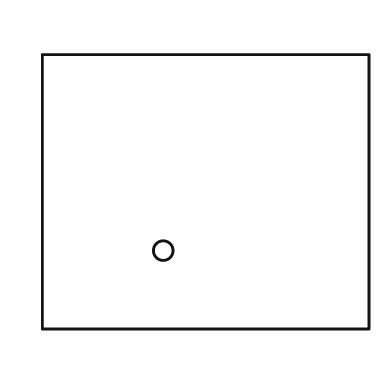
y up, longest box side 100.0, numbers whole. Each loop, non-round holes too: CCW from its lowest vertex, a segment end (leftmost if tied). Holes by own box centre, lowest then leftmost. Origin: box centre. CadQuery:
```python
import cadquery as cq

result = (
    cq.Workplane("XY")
    .moveTo(-50.0, -42.0)
    .lineTo(50.0, -42.0)
    .lineTo(50.0, 42.0)
    .lineTo(-50.0, 42.0)
    .close()
    .moveTo(-13.0, -18.0)
    .circle(3.0)
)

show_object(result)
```